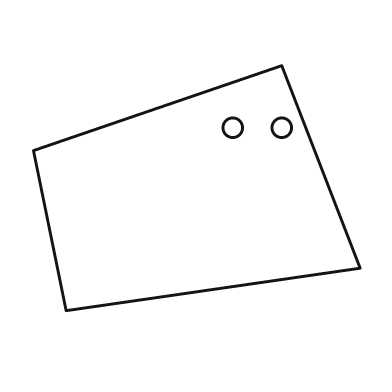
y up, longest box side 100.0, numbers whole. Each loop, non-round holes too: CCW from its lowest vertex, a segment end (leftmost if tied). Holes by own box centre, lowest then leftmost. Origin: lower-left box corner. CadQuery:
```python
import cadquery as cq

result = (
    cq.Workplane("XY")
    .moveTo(10.0, 0.0)
    .lineTo(100.0, 13.0)
    .lineTo(76.0, 75.0)
    .lineTo(0.0, 49.0)
    .close()
    .moveTo(61.0, 56.0)
    .circle(3.0)
    .moveTo(76.0, 56.0)
    .circle(3.0)
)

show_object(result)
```